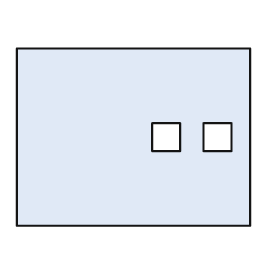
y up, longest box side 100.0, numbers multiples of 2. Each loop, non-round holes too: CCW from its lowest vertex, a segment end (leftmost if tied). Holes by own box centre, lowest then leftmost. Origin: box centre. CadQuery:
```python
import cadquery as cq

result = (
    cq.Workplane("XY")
    .moveTo(-50.0, -38.0)
    .lineTo(50.0, -38.0)
    .lineTo(50.0, 38.0)
    .lineTo(-50.0, 38.0)
    .close()
    .moveTo(8.0, -6.0)
    .lineTo(20.0, -6.0)
    .lineTo(20.0, 6.0)
    .lineTo(8.0, 6.0)
    .close()
    .moveTo(30.0, -6.0)
    .lineTo(42.0, -6.0)
    .lineTo(42.0, 6.0)
    .lineTo(30.0, 6.0)
    .close()
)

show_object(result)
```